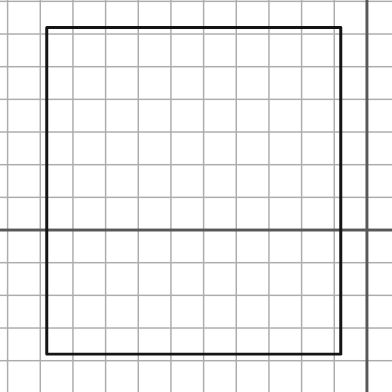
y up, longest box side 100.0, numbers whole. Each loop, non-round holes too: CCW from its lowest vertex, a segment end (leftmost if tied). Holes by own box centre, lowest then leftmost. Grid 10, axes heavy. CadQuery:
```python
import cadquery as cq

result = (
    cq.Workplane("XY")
    .moveTo(-98.0, -38.0)
    .lineTo(-8.0, -38.0)
    .lineTo(-8.0, 62.0)
    .lineTo(-98.0, 62.0)
    .close()
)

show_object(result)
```